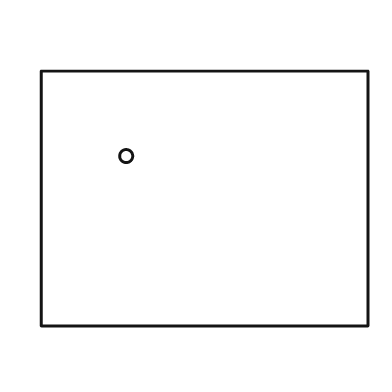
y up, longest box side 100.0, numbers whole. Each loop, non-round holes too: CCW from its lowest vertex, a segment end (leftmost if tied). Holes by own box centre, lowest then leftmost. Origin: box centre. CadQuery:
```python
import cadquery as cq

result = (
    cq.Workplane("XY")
    .moveTo(-50.0, -39.0)
    .lineTo(50.0, -39.0)
    .lineTo(50.0, 39.0)
    .lineTo(-50.0, 39.0)
    .close()
    .moveTo(-24.0, 13.0)
    .circle(2.0)
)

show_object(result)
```